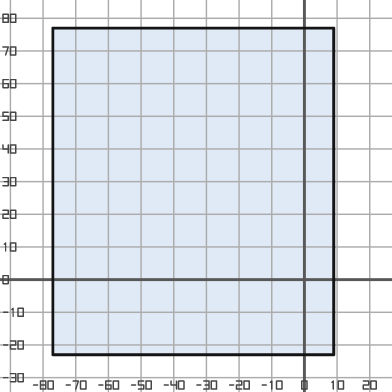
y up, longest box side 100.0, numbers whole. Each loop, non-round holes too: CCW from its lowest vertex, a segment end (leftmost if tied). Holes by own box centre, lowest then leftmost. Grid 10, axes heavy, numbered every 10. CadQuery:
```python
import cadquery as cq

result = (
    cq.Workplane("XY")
    .moveTo(-77.0, -23.0)
    .lineTo(9.0, -23.0)
    .lineTo(9.0, 77.0)
    .lineTo(-77.0, 77.0)
    .close()
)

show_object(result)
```